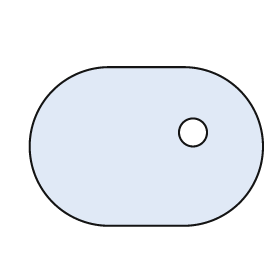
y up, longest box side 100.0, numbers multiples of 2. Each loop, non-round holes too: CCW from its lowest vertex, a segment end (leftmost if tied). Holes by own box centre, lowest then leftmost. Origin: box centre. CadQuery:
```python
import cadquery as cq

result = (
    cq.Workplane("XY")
    .moveTo(-16.0, -34.0)
    .lineTo(16.0, -34.0)
    .threePointArc((50.0, 0.0), (16.0, 34.0))
    .lineTo(-16.0, 34.0)
    .threePointArc((-50.0, 0.0), (-16.0, -34.0))
    .close()
    .moveTo(20.0, 6.0)
    .circle(6.0)
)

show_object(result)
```